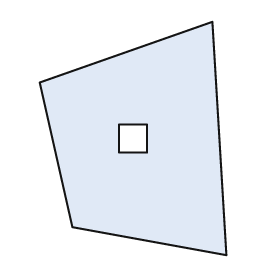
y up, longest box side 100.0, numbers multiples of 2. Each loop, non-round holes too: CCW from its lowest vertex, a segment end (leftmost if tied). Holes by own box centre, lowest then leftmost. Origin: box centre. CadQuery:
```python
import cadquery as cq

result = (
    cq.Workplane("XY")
    .moveTo(40.0, -50.0)
    .lineTo(34.0, 50.0)
    .lineTo(-40.0, 24.0)
    .lineTo(-26.0, -38.0)
    .close()
    .moveTo(-6.0, -6.0)
    .lineTo(6.0, -6.0)
    .lineTo(6.0, 6.0)
    .lineTo(-6.0, 6.0)
    .close()
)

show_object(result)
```